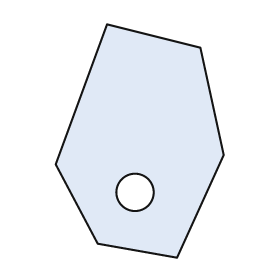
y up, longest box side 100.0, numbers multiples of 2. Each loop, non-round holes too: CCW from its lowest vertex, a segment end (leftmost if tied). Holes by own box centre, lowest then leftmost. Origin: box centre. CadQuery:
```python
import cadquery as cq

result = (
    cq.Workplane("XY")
    .moveTo(16.0, -50.0)
    .lineTo(36.0, -6.0)
    .lineTo(26.0, 40.0)
    .lineTo(-14.0, 50.0)
    .lineTo(-36.0, -10.0)
    .lineTo(-18.0, -44.0)
    .close()
    .moveTo(-2.0, -22.0)
    .circle(8.0)
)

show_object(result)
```